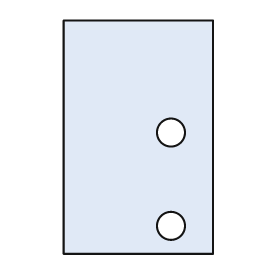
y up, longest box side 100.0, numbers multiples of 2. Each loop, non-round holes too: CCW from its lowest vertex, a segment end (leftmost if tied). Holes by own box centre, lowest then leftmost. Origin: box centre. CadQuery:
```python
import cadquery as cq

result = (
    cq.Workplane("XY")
    .moveTo(-32.0, -50.0)
    .lineTo(32.0, -50.0)
    .lineTo(32.0, 50.0)
    .lineTo(-32.0, 50.0)
    .close()
    .moveTo(14.0, -38.0)
    .circle(6.0)
    .moveTo(14.0, 2.0)
    .circle(6.0)
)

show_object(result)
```